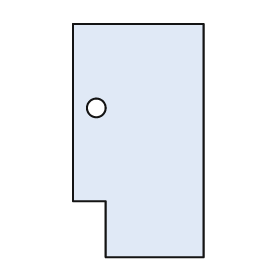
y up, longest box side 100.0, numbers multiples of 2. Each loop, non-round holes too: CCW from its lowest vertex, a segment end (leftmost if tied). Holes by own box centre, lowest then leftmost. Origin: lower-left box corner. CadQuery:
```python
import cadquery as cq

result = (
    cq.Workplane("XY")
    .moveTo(14.0, 0.0)
    .lineTo(56.0, 0.0)
    .lineTo(56.0, 100.0)
    .lineTo(0.0, 100.0)
    .lineTo(0.0, 24.0)
    .lineTo(14.0, 24.0)
    .close()
    .moveTo(10.0, 64.0)
    .circle(4.0)
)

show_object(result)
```